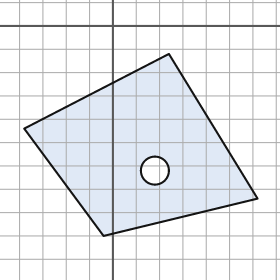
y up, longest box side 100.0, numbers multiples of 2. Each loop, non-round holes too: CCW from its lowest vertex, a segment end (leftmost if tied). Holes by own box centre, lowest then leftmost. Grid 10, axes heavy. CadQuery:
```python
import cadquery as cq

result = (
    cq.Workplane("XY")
    .moveTo(-4.0, -90.0)
    .lineTo(62.0, -74.0)
    .lineTo(24.0, -12.0)
    .lineTo(-38.0, -44.0)
    .close()
    .moveTo(18.0, -62.0)
    .circle(6.0)
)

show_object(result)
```